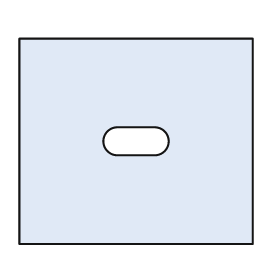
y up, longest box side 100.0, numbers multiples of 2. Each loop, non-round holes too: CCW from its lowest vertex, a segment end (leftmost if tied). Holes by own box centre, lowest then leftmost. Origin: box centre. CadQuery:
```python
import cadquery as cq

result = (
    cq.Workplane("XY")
    .moveTo(-50.0, -44.0)
    .lineTo(50.0, -44.0)
    .lineTo(50.0, 44.0)
    .lineTo(-50.0, 44.0)
    .close()
    .moveTo(-8.0, -6.0)
    .lineTo(8.0, -6.0)
    .threePointArc((14.0, 0.0), (8.0, 6.0))
    .lineTo(-8.0, 6.0)
    .threePointArc((-14.0, 0.0), (-8.0, -6.0))
    .close()
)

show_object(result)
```